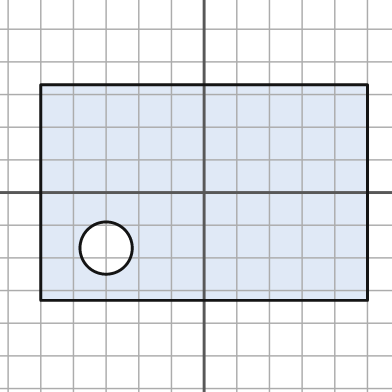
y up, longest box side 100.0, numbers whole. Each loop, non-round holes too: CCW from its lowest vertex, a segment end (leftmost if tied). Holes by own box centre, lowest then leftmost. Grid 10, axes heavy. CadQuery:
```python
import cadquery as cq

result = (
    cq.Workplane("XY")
    .moveTo(-50.0, -33.0)
    .lineTo(50.0, -33.0)
    .lineTo(50.0, 33.0)
    .lineTo(-50.0, 33.0)
    .close()
    .moveTo(-30.0, -17.0)
    .circle(8.0)
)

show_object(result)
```